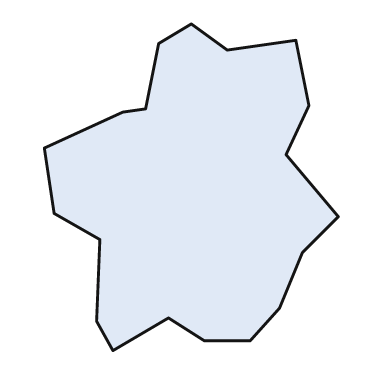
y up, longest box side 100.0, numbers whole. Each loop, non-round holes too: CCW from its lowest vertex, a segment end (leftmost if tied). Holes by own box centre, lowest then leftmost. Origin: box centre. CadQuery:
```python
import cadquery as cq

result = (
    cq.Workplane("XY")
    .moveTo(-24.0, -50.0)
    .lineTo(-7.0, -40.0)
    .lineTo(4.0, -47.0)
    .lineTo(18.0, -47.0)
    .lineTo(27.0, -37.0)
    .lineTo(34.0, -20.0)
    .lineTo(45.0, -9.0)
    .lineTo(29.0, 10.0)
    .lineTo(36.0, 25.0)
    .lineTo(32.0, 45.0)
    .lineTo(11.0, 42.0)
    .lineTo(0.0, 50.0)
    .lineTo(-10.0, 44.0)
    .lineTo(-14.0, 24.0)
    .lineTo(-21.0, 23.0)
    .lineTo(-45.0, 12.0)
    .lineTo(-42.0, -8.0)
    .lineTo(-28.0, -16.0)
    .lineTo(-29.0, -41.0)
    .close()
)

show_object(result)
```